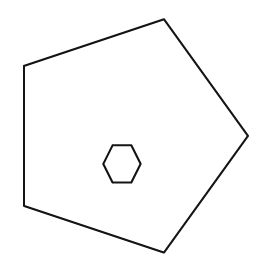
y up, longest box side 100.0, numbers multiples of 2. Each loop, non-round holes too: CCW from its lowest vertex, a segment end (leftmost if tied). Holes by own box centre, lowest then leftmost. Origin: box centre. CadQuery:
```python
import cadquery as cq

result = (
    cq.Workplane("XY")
    .moveTo(12.0, -50.0)
    .lineTo(48.0, 0.0)
    .lineTo(12.0, 50.0)
    .lineTo(-48.0, 30.0)
    .lineTo(-48.0, -30.0)
    .close()
    .moveTo(-10.0, -20.0)
    .lineTo(-2.0, -20.0)
    .lineTo(2.0, -12.0)
    .lineTo(-2.0, -4.0)
    .lineTo(-10.0, -4.0)
    .lineTo(-14.0, -12.0)
    .close()
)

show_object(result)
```